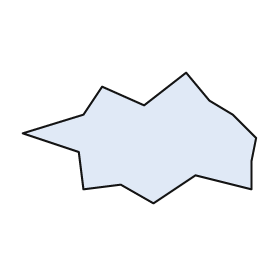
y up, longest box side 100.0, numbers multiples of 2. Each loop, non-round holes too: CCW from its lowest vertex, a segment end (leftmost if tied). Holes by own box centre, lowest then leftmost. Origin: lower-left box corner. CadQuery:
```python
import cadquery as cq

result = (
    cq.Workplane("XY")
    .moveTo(56.0, 0.0)
    .lineTo(74.0, 12.0)
    .lineTo(98.0, 6.0)
    .lineTo(98.0, 18.0)
    .lineTo(100.0, 28.0)
    .lineTo(90.0, 38.0)
    .lineTo(80.0, 44.0)
    .lineTo(70.0, 56.0)
    .lineTo(52.0, 42.0)
    .lineTo(34.0, 50.0)
    .lineTo(26.0, 38.0)
    .lineTo(0.0, 30.0)
    .lineTo(24.0, 22.0)
    .lineTo(26.0, 6.0)
    .lineTo(42.0, 8.0)
    .close()
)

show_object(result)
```